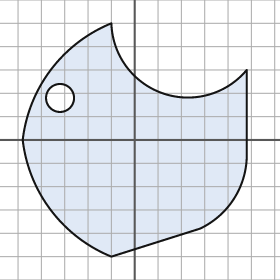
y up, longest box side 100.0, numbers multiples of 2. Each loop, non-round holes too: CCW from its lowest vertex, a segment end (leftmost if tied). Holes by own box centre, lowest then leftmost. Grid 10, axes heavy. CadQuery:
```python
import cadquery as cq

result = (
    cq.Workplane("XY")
    .moveTo(-10.0, -50.0)
    .lineTo(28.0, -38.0)
    .threePointArc((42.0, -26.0), (48.0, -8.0))
    .lineTo(48.0, 30.0)
    .threePointArc((12.0, 20.0), (-10.0, 50.0))
    .threePointArc((-36.0, 30.0), (-48.0, 0.0))
    .threePointArc((-36.0, -30.0), (-10.0, -50.0))
    .close()
    .moveTo(-32.0, 18.0)
    .circle(6.0)
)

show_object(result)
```